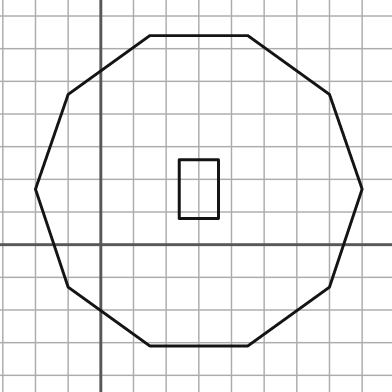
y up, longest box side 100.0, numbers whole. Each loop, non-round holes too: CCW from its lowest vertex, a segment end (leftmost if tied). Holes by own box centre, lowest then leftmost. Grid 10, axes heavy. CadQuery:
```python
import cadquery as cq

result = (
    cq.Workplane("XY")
    .moveTo(15.0, -31.0)
    .lineTo(45.0, -31.0)
    .lineTo(70.0, -13.0)
    .lineTo(80.0, 17.0)
    .lineTo(70.0, 46.0)
    .lineTo(45.0, 64.0)
    .lineTo(15.0, 64.0)
    .lineTo(-10.0, 46.0)
    .lineTo(-20.0, 17.0)
    .lineTo(-10.0, -13.0)
    .close()
    .moveTo(24.0, 8.0)
    .lineTo(36.0, 8.0)
    .lineTo(36.0, 26.0)
    .lineTo(24.0, 26.0)
    .close()
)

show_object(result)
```